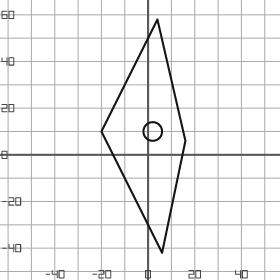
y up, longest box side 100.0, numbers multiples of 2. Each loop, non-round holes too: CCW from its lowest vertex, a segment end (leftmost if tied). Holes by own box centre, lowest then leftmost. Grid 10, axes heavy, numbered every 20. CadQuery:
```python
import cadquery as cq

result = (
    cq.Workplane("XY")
    .moveTo(6.0, -42.0)
    .lineTo(16.0, 6.0)
    .lineTo(4.0, 58.0)
    .lineTo(-20.0, 10.0)
    .close()
    .moveTo(2.0, 10.0)
    .circle(4.0)
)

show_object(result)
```